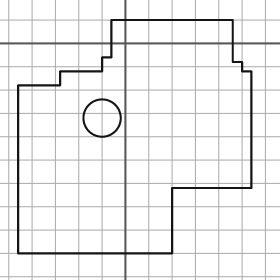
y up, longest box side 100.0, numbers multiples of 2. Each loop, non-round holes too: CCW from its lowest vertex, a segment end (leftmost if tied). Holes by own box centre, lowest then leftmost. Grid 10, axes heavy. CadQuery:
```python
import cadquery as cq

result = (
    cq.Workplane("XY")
    .moveTo(-46.0, -90.0)
    .lineTo(20.0, -90.0)
    .lineTo(20.0, -62.0)
    .lineTo(54.0, -62.0)
    .lineTo(54.0, -12.0)
    .lineTo(50.0, -12.0)
    .lineTo(50.0, -8.0)
    .lineTo(46.0, -8.0)
    .lineTo(46.0, 10.0)
    .lineTo(-6.0, 10.0)
    .lineTo(-6.0, -6.0)
    .lineTo(-10.0, -6.0)
    .lineTo(-10.0, -12.0)
    .lineTo(-28.0, -12.0)
    .lineTo(-28.0, -18.0)
    .lineTo(-46.0, -18.0)
    .close()
    .moveTo(-10.0, -32.0)
    .circle(8.0)
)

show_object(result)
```